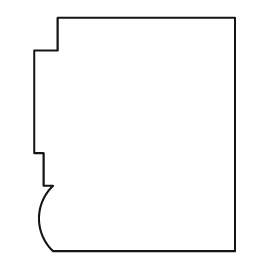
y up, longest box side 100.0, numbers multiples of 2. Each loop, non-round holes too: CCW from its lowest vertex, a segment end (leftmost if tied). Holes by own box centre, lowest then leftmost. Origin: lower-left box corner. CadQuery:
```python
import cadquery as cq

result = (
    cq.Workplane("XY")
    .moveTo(8.0, 0.0)
    .lineTo(86.0, 0.0)
    .lineTo(86.0, 100.0)
    .lineTo(10.0, 100.0)
    .lineTo(10.0, 86.0)
    .lineTo(0.0, 86.0)
    .lineTo(0.0, 42.0)
    .lineTo(4.0, 42.0)
    .lineTo(4.0, 28.0)
    .lineTo(8.0, 28.0)
    .threePointArc((2.0, 14.0), (8.0, 0.0))
    .close()
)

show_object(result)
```